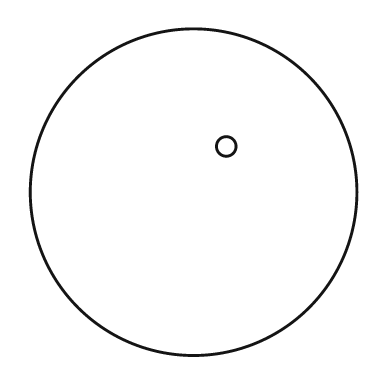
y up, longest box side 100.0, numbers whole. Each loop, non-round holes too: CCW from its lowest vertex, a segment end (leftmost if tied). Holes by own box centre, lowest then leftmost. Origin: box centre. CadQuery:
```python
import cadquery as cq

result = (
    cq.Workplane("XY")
    .moveTo(0.0, 0.0)
    .circle(50.0)
    .moveTo(10.0, 14.0)
    .circle(3.0)
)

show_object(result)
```